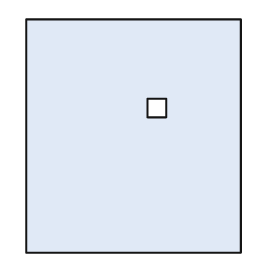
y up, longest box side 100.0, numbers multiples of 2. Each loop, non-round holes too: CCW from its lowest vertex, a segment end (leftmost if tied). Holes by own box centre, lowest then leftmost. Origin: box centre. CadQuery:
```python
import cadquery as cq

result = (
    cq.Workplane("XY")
    .moveTo(-46.0, -50.0)
    .lineTo(46.0, -50.0)
    .lineTo(46.0, 50.0)
    .lineTo(-46.0, 50.0)
    .close()
    .moveTo(6.0, 8.0)
    .lineTo(14.0, 8.0)
    .lineTo(14.0, 16.0)
    .lineTo(6.0, 16.0)
    .close()
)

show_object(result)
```